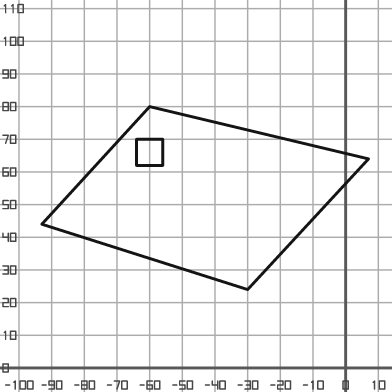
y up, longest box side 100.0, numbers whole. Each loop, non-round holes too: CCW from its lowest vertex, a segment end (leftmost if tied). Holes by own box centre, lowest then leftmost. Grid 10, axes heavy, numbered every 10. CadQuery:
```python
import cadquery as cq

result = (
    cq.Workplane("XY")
    .moveTo(-30.0, 24.0)
    .lineTo(7.0, 64.0)
    .lineTo(-60.0, 80.0)
    .lineTo(-93.0, 44.0)
    .close()
    .moveTo(-64.0, 62.0)
    .lineTo(-56.0, 62.0)
    .lineTo(-56.0, 70.0)
    .lineTo(-64.0, 70.0)
    .close()
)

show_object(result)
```